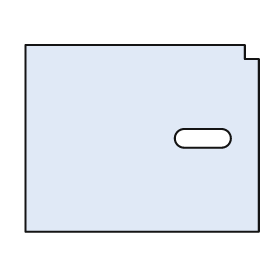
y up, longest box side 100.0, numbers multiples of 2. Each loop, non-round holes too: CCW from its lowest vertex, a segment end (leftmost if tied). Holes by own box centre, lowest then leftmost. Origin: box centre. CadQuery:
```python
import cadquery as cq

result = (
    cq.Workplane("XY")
    .moveTo(-50.0, -40.0)
    .lineTo(50.0, -40.0)
    .lineTo(50.0, 34.0)
    .lineTo(44.0, 34.0)
    .lineTo(44.0, 40.0)
    .lineTo(-50.0, 40.0)
    .close()
    .moveTo(18.0, -4.0)
    .lineTo(34.0, -4.0)
    .threePointArc((38.0, 0.0), (34.0, 4.0))
    .lineTo(18.0, 4.0)
    .threePointArc((14.0, 0.0), (18.0, -4.0))
    .close()
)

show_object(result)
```